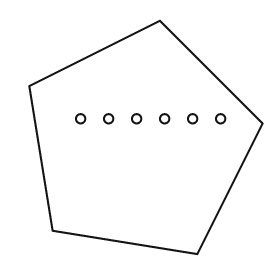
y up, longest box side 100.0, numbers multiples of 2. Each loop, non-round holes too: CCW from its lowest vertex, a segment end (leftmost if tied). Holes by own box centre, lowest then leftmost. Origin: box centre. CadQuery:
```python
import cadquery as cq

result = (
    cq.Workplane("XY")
    .moveTo(22.0, -50.0)
    .lineTo(50.0, 6.0)
    .lineTo(6.0, 50.0)
    .lineTo(-50.0, 22.0)
    .lineTo(-40.0, -40.0)
    .close()
    .moveTo(-28.0, 8.0)
    .circle(2.0)
    .moveTo(-16.0, 8.0)
    .circle(2.0)
    .moveTo(-4.0, 8.0)
    .circle(2.0)
    .moveTo(8.0, 8.0)
    .circle(2.0)
    .moveTo(20.0, 8.0)
    .circle(2.0)
    .moveTo(32.0, 8.0)
    .circle(2.0)
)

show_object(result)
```